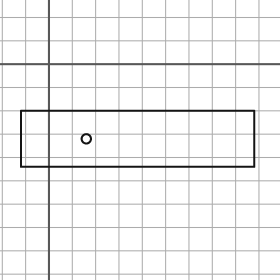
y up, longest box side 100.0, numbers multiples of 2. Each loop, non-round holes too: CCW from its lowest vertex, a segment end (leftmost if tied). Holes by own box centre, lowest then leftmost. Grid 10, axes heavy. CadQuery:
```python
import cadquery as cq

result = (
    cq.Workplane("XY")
    .moveTo(-12.0, -44.0)
    .lineTo(88.0, -44.0)
    .lineTo(88.0, -20.0)
    .lineTo(-12.0, -20.0)
    .close()
    .moveTo(16.0, -32.0)
    .circle(2.0)
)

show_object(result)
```